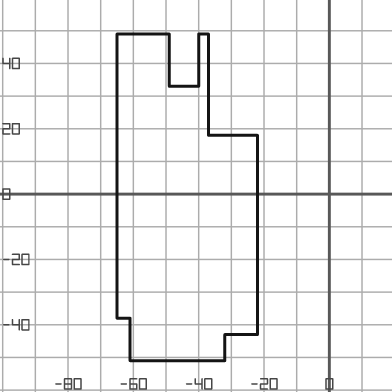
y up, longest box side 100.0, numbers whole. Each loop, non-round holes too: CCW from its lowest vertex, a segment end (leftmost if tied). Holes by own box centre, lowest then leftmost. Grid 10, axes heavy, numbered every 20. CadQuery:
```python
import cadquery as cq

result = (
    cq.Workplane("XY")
    .moveTo(-61.0, -51.0)
    .lineTo(-32.0, -51.0)
    .lineTo(-32.0, -43.0)
    .lineTo(-22.0, -43.0)
    .lineTo(-22.0, 18.0)
    .lineTo(-37.0, 18.0)
    .lineTo(-37.0, 49.0)
    .lineTo(-40.0, 49.0)
    .lineTo(-40.0, 33.0)
    .lineTo(-49.0, 33.0)
    .lineTo(-49.0, 49.0)
    .lineTo(-65.0, 49.0)
    .lineTo(-65.0, -38.0)
    .lineTo(-61.0, -38.0)
    .close()
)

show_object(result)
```